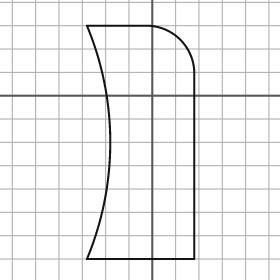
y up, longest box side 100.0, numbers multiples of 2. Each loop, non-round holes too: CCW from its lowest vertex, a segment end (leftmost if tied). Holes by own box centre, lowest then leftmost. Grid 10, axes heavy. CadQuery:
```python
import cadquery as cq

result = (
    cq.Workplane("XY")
    .moveTo(-28.0, -70.0)
    .lineTo(18.0, -70.0)
    .lineTo(18.0, 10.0)
    .threePointArc((12.0, 24.0), (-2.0, 30.0))
    .lineTo(-28.0, 30.0)
    .threePointArc((-18.0, -20.0), (-28.0, -70.0))
    .close()
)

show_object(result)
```